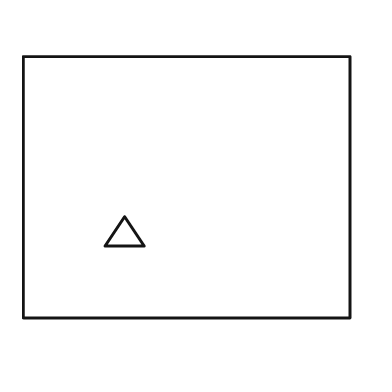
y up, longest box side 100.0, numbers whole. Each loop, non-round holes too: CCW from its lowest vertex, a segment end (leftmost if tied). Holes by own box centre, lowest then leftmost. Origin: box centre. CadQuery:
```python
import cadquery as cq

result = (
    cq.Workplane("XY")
    .moveTo(-50.0, -40.0)
    .lineTo(50.0, -40.0)
    .lineTo(50.0, 40.0)
    .lineTo(-50.0, 40.0)
    .close()
    .moveTo(-25.0, -18.0)
    .lineTo(-13.0, -18.0)
    .lineTo(-19.0, -9.0)
    .close()
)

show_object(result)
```